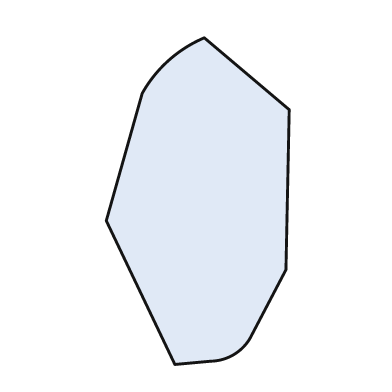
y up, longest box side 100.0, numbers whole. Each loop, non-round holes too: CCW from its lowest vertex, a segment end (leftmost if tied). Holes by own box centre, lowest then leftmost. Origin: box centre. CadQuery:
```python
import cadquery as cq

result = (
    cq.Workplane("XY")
    .moveTo(-7.0, -50.0)
    .lineTo(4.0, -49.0)
    .threePointArc((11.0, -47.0), (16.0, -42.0))
    .lineTo(27.0, -21.0)
    .lineTo(28.0, 28.0)
    .lineTo(2.0, 50.0)
    .threePointArc((-9.0, 43.0), (-17.0, 33.0))
    .lineTo(-28.0, -6.0)
    .close()
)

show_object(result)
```